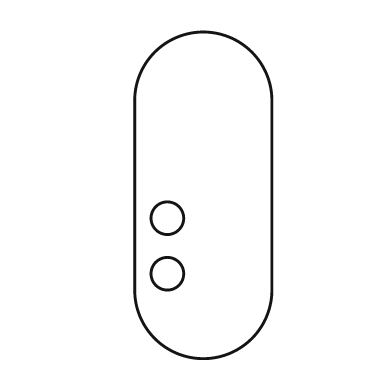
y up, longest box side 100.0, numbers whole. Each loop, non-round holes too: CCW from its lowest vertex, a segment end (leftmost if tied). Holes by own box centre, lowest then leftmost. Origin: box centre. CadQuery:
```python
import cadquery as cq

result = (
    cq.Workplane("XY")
    .moveTo(-21.0, -29.0)
    .threePointArc((0.0, -50.0), (21.0, -29.0))
    .lineTo(21.0, 29.0)
    .threePointArc((0.0, 50.0), (-21.0, 29.0))
    .close()
    .moveTo(-11.0, -24.0)
    .circle(5.0)
    .moveTo(-11.0, -7.0)
    .circle(5.0)
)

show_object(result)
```